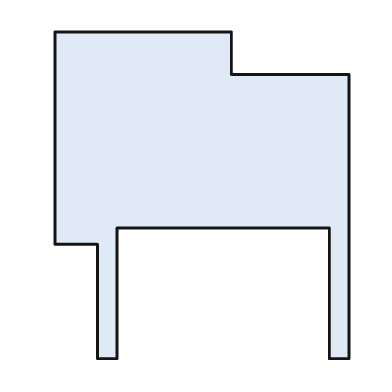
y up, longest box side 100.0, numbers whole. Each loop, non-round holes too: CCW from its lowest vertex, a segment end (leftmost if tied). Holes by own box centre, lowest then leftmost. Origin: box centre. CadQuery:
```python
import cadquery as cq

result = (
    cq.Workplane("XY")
    .moveTo(-32.0, -50.0)
    .lineTo(-26.0, -50.0)
    .lineTo(-26.0, -10.0)
    .lineTo(39.0, -10.0)
    .lineTo(39.0, -50.0)
    .lineTo(45.0, -50.0)
    .lineTo(45.0, 37.0)
    .lineTo(9.0, 37.0)
    .lineTo(9.0, 50.0)
    .lineTo(-45.0, 50.0)
    .lineTo(-45.0, -15.0)
    .lineTo(-32.0, -15.0)
    .close()
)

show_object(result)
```